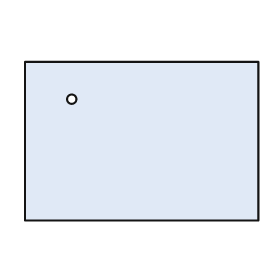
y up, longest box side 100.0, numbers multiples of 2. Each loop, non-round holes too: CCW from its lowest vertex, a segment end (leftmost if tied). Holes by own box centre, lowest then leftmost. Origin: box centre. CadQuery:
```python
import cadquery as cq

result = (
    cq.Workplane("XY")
    .moveTo(-50.0, -34.0)
    .lineTo(50.0, -34.0)
    .lineTo(50.0, 34.0)
    .lineTo(-50.0, 34.0)
    .close()
    .moveTo(-30.0, 18.0)
    .circle(2.0)
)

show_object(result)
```